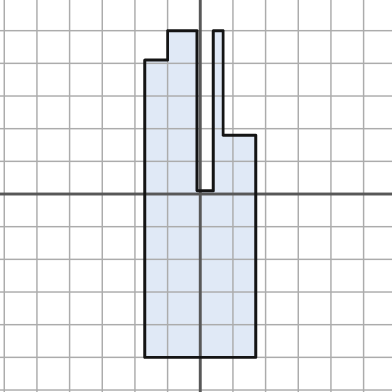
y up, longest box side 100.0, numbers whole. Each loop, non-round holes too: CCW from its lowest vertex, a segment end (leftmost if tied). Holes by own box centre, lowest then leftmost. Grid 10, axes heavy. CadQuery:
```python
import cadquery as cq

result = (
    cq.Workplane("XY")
    .moveTo(-17.0, -50.0)
    .lineTo(17.0, -50.0)
    .lineTo(17.0, 18.0)
    .lineTo(7.0, 18.0)
    .lineTo(7.0, 50.0)
    .lineTo(4.0, 50.0)
    .lineTo(4.0, 1.0)
    .lineTo(-1.0, 1.0)
    .lineTo(-1.0, 50.0)
    .lineTo(-10.0, 50.0)
    .lineTo(-10.0, 41.0)
    .lineTo(-17.0, 41.0)
    .close()
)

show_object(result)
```